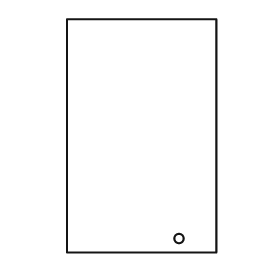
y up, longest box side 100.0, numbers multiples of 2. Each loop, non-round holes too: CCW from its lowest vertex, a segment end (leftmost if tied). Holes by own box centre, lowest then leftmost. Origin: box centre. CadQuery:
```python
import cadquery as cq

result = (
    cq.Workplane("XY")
    .moveTo(-32.0, -50.0)
    .lineTo(32.0, -50.0)
    .lineTo(32.0, 50.0)
    .lineTo(-32.0, 50.0)
    .close()
    .moveTo(16.0, -44.0)
    .circle(2.0)
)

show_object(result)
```